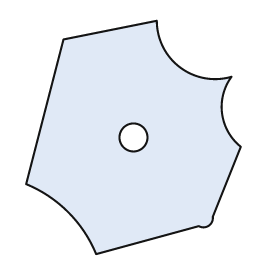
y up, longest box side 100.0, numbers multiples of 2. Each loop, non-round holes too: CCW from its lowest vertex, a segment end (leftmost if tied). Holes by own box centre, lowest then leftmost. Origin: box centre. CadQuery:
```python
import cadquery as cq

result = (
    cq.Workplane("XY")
    .moveTo(-16.0, -50.0)
    .lineTo(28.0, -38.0)
    .threePointArc((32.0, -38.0), (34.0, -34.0))
    .lineTo(46.0, -4.0)
    .threePointArc((38.0, 10.0), (42.0, 26.0))
    .threePointArc((20.0, 30.0), (10.0, 50.0))
    .lineTo(-30.0, 42.0)
    .lineTo(-46.0, -20.0)
    .threePointArc((-28.0, -32.0), (-16.0, -50.0))
    .close()
    .moveTo(0.0, 0.0)
    .circle(6.0)
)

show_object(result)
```